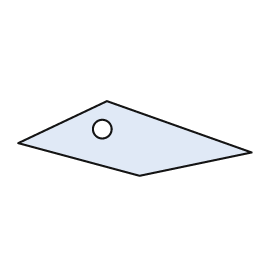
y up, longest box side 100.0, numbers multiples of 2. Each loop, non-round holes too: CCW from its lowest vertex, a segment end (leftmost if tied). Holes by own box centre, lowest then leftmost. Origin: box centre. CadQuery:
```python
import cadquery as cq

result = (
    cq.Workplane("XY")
    .moveTo(2.0, -16.0)
    .lineTo(50.0, -6.0)
    .lineTo(-12.0, 16.0)
    .lineTo(-50.0, -2.0)
    .close()
    .moveTo(-14.0, 4.0)
    .circle(4.0)
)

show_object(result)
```